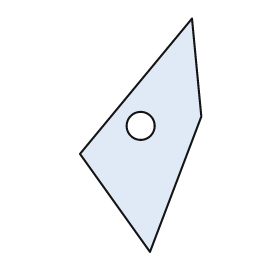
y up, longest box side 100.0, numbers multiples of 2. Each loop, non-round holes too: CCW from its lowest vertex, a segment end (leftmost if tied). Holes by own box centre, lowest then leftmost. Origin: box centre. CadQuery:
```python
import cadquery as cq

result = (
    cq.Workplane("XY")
    .moveTo(4.0, -50.0)
    .lineTo(26.0, 8.0)
    .lineTo(22.0, 50.0)
    .lineTo(-26.0, -8.0)
    .close()
    .moveTo(0.0, 4.0)
    .circle(6.0)
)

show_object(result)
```